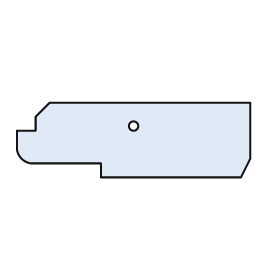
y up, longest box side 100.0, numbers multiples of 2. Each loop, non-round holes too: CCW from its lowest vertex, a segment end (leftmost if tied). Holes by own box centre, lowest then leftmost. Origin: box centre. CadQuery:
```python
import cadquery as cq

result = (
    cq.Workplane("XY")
    .moveTo(-14.0, -16.0)
    .lineTo(46.0, -16.0)
    .lineTo(50.0, -8.0)
    .lineTo(50.0, 16.0)
    .lineTo(-36.0, 16.0)
    .lineTo(-42.0, 10.0)
    .lineTo(-42.0, 4.0)
    .lineTo(-50.0, 4.0)
    .lineTo(-50.0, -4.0)
    .threePointArc((-48.0, -8.0), (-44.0, -10.0))
    .lineTo(-14.0, -10.0)
    .close()
    .moveTo(0.0, 6.0)
    .circle(2.0)
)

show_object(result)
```